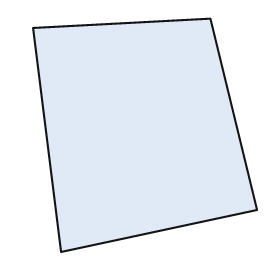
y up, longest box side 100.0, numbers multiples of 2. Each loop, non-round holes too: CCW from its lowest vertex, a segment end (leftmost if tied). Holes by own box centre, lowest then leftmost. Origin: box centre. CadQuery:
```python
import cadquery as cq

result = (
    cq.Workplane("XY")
    .moveTo(-36.0, -50.0)
    .lineTo(48.0, -32.0)
    .lineTo(28.0, 50.0)
    .lineTo(-48.0, 46.0)
    .close()
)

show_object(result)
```